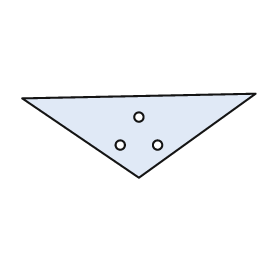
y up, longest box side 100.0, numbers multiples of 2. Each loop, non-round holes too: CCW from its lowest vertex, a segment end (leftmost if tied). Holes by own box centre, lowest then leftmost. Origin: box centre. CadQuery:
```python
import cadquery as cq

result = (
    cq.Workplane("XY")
    .moveTo(0.0, -18.0)
    .lineTo(50.0, 18.0)
    .lineTo(-50.0, 16.0)
    .close()
    .moveTo(-8.0, -4.0)
    .circle(2.0)
    .moveTo(8.0, -4.0)
    .circle(2.0)
    .moveTo(0.0, 8.0)
    .circle(2.0)
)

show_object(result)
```